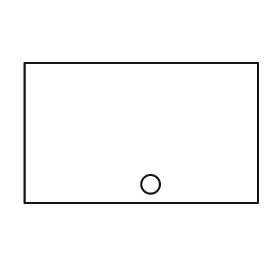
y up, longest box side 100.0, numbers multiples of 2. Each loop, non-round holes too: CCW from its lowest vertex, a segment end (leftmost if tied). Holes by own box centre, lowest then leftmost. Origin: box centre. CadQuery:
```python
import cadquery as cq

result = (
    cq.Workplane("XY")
    .moveTo(-50.0, -30.0)
    .lineTo(50.0, -30.0)
    .lineTo(50.0, 30.0)
    .lineTo(-50.0, 30.0)
    .close()
    .moveTo(4.0, -22.0)
    .circle(4.0)
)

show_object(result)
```